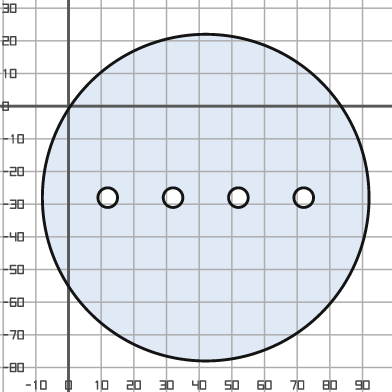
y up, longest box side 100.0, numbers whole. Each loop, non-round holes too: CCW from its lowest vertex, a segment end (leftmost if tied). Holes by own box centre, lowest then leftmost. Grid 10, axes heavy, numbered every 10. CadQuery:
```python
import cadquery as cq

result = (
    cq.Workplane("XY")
    .moveTo(42.0, -28.0)
    .circle(50.0)
    .moveTo(12.0, -28.0)
    .circle(3.0)
    .moveTo(32.0, -28.0)
    .circle(3.0)
    .moveTo(52.0, -28.0)
    .circle(3.0)
    .moveTo(72.0, -28.0)
    .circle(3.0)
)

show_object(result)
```